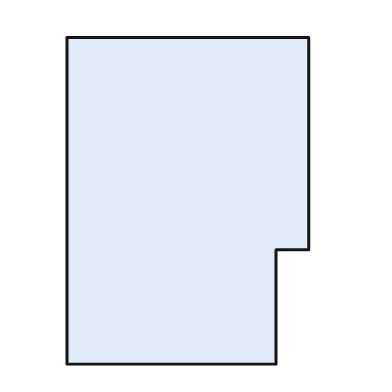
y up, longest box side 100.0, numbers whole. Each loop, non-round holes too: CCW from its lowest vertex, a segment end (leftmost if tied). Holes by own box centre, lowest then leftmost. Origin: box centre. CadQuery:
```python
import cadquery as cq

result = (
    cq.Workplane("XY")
    .moveTo(-37.0, -50.0)
    .lineTo(27.0, -50.0)
    .lineTo(27.0, -15.0)
    .lineTo(37.0, -15.0)
    .lineTo(37.0, 50.0)
    .lineTo(-37.0, 50.0)
    .close()
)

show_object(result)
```